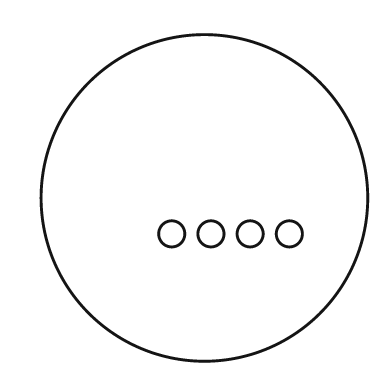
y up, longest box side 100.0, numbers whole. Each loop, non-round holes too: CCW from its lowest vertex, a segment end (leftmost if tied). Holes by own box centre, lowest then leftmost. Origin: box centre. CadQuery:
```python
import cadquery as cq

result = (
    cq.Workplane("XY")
    .moveTo(0.0, 0.0)
    .circle(50.0)
    .moveTo(-10.0, -11.0)
    .circle(4.0)
    .moveTo(2.0, -11.0)
    .circle(4.0)
    .moveTo(14.0, -11.0)
    .circle(4.0)
    .moveTo(26.0, -11.0)
    .circle(4.0)
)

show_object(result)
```